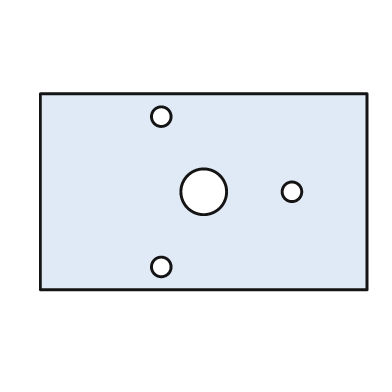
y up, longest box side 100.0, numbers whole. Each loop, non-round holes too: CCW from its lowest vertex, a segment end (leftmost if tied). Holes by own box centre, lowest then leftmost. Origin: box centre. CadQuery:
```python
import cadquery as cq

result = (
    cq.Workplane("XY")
    .moveTo(-50.0, -30.0)
    .lineTo(50.0, -30.0)
    .lineTo(50.0, 30.0)
    .lineTo(-50.0, 30.0)
    .close()
    .moveTo(-13.0, -23.0)
    .circle(3.0)
    .moveTo(0.0, 0.0)
    .circle(7.0)
    .moveTo(27.0, 0.0)
    .circle(3.0)
    .moveTo(-13.0, 23.0)
    .circle(3.0)
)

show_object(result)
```